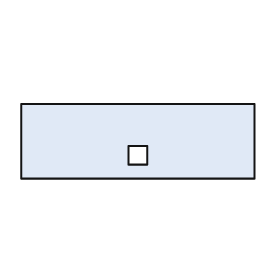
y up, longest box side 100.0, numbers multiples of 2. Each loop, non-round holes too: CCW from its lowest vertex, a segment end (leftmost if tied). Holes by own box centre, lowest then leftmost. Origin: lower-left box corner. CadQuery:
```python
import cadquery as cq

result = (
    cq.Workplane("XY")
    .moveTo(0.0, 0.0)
    .lineTo(100.0, 0.0)
    .lineTo(100.0, 32.0)
    .lineTo(0.0, 32.0)
    .close()
    .moveTo(46.0, 6.0)
    .lineTo(54.0, 6.0)
    .lineTo(54.0, 14.0)
    .lineTo(46.0, 14.0)
    .close()
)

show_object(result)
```